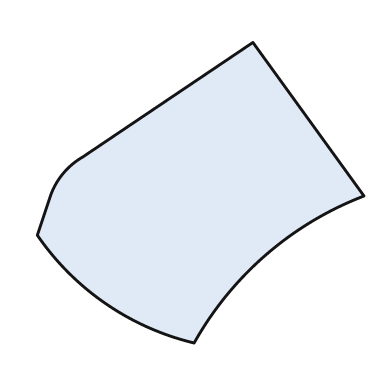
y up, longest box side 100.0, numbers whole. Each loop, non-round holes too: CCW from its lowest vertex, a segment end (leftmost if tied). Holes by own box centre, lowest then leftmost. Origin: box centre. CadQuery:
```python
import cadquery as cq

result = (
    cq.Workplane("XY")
    .moveTo(-2.0, -46.0)
    .threePointArc((20.0, -19.0), (50.0, -1.0))
    .lineTo(16.0, 46.0)
    .lineTo(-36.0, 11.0)
    .threePointArc((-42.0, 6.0), (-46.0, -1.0))
    .lineTo(-50.0, -13.0)
    .threePointArc((-29.0, -34.0), (-2.0, -46.0))
    .close()
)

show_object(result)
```